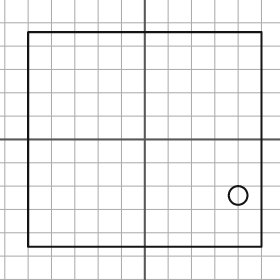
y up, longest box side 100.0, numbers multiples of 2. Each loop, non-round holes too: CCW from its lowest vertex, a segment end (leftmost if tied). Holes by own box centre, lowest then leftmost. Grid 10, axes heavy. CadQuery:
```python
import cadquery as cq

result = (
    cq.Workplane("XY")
    .moveTo(-50.0, -46.0)
    .lineTo(50.0, -46.0)
    .lineTo(50.0, 46.0)
    .lineTo(-50.0, 46.0)
    .close()
    .moveTo(40.0, -24.0)
    .circle(4.0)
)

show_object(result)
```